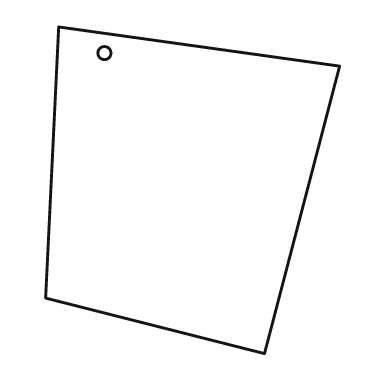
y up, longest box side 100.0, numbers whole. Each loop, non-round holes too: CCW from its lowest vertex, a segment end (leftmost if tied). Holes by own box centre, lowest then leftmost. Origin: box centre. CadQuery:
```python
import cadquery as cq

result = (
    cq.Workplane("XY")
    .moveTo(22.0, -50.0)
    .lineTo(45.0, 38.0)
    .lineTo(-41.0, 50.0)
    .lineTo(-45.0, -33.0)
    .close()
    .moveTo(-27.0, 42.0)
    .circle(2.0)
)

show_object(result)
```